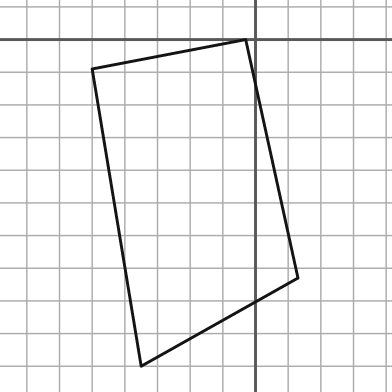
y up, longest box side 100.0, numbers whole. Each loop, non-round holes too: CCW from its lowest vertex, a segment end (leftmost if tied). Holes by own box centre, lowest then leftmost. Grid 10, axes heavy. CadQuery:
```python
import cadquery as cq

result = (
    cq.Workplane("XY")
    .moveTo(-35.0, -100.0)
    .lineTo(13.0, -73.0)
    .lineTo(-3.0, 0.0)
    .lineTo(-50.0, -9.0)
    .close()
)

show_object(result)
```